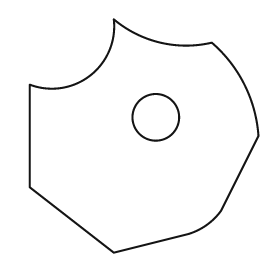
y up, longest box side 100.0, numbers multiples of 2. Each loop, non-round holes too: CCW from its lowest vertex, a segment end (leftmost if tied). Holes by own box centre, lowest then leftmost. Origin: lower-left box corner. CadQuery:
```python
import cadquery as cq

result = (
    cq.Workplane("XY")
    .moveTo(36.0, 0.0)
    .lineTo(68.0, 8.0)
    .threePointArc((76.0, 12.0), (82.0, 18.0))
    .lineTo(98.0, 50.0)
    .threePointArc((92.0, 72.0), (78.0, 90.0))
    .threePointArc((56.0, 90.0), (36.0, 100.0))
    .threePointArc((26.0, 76.0), (0.0, 72.0))
    .lineTo(0.0, 28.0)
    .close()
    .moveTo(54.0, 58.0)
    .circle(10.0)
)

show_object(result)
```